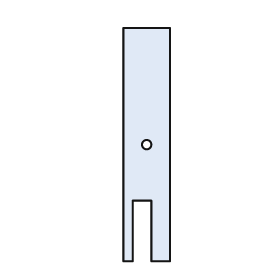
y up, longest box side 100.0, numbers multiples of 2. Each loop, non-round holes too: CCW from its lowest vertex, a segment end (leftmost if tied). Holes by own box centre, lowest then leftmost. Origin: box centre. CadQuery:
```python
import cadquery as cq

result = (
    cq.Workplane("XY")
    .moveTo(-10.0, -50.0)
    .lineTo(-6.0, -50.0)
    .lineTo(-6.0, -24.0)
    .lineTo(2.0, -24.0)
    .lineTo(2.0, -50.0)
    .lineTo(10.0, -50.0)
    .lineTo(10.0, 50.0)
    .lineTo(-10.0, 50.0)
    .close()
    .moveTo(0.0, 0.0)
    .circle(2.0)
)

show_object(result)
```